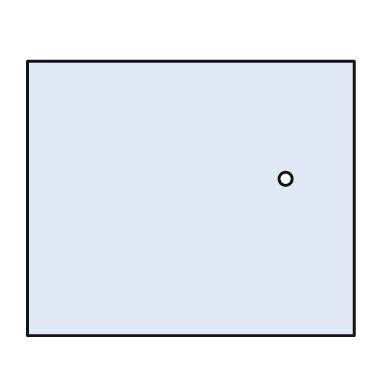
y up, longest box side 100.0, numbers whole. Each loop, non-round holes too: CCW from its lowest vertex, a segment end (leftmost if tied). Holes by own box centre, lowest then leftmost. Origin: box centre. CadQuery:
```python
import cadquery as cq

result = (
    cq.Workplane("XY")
    .moveTo(-50.0, -42.0)
    .lineTo(50.0, -42.0)
    .lineTo(50.0, 42.0)
    .lineTo(-50.0, 42.0)
    .close()
    .moveTo(29.0, 6.0)
    .circle(2.0)
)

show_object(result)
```